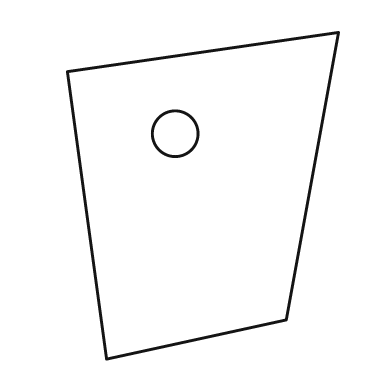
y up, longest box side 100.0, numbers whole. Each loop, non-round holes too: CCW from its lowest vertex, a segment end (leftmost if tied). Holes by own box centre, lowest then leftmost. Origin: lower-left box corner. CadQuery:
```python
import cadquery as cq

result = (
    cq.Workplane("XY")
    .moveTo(12.0, 0.0)
    .lineTo(67.0, 12.0)
    .lineTo(83.0, 100.0)
    .lineTo(0.0, 88.0)
    .close()
    .moveTo(33.0, 69.0)
    .circle(7.0)
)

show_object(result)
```